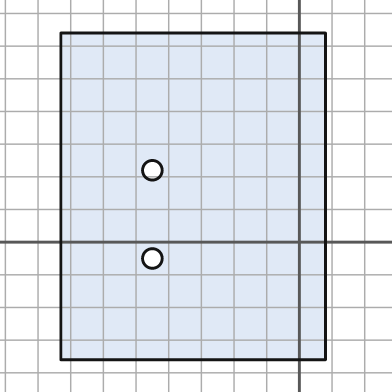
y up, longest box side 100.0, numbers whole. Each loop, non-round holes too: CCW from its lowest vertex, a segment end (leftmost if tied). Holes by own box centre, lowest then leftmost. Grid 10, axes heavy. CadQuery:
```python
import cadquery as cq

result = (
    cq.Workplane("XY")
    .moveTo(-73.0, -36.0)
    .lineTo(8.0, -36.0)
    .lineTo(8.0, 64.0)
    .lineTo(-73.0, 64.0)
    .close()
    .moveTo(-45.0, -5.0)
    .circle(3.0)
    .moveTo(-45.0, 22.0)
    .circle(3.0)
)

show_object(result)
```